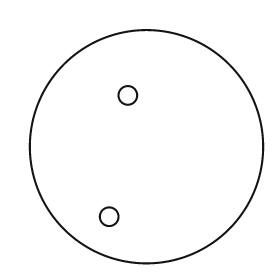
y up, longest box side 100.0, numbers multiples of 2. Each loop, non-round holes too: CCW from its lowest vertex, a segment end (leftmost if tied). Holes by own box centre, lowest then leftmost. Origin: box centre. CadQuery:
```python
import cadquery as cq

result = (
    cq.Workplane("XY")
    .moveTo(0.0, 0.0)
    .circle(50.0)
    .moveTo(-16.0, -30.0)
    .circle(4.0)
    .moveTo(-8.0, 22.0)
    .circle(4.0)
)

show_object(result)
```